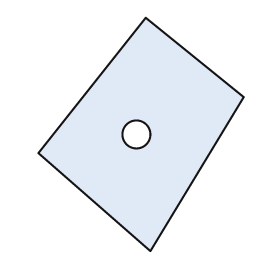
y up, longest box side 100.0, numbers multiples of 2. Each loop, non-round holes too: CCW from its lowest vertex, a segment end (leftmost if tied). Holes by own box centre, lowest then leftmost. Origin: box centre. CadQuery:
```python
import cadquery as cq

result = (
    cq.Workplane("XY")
    .moveTo(4.0, -50.0)
    .lineTo(44.0, 16.0)
    .lineTo(2.0, 50.0)
    .lineTo(-44.0, -8.0)
    .close()
    .moveTo(-2.0, 0.0)
    .circle(6.0)
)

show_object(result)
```